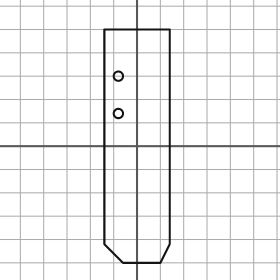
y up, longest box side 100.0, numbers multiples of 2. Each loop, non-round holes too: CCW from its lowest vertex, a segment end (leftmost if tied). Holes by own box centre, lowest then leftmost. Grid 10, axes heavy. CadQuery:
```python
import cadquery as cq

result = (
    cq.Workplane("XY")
    .moveTo(-6.0, -50.0)
    .lineTo(10.0, -50.0)
    .lineTo(14.0, -42.0)
    .lineTo(14.0, 50.0)
    .lineTo(-14.0, 50.0)
    .lineTo(-14.0, -42.0)
    .close()
    .moveTo(-8.0, 14.0)
    .circle(2.0)
    .moveTo(-8.0, 30.0)
    .circle(2.0)
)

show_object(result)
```